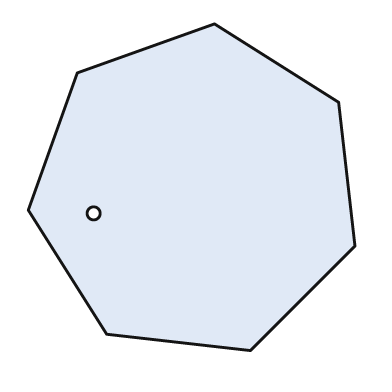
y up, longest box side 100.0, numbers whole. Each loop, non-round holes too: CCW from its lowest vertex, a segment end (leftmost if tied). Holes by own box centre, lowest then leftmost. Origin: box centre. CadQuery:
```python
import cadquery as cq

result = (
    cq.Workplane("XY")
    .moveTo(18.0, -50.0)
    .lineTo(50.0, -18.0)
    .lineTo(45.0, 26.0)
    .lineTo(7.0, 50.0)
    .lineTo(-35.0, 35.0)
    .lineTo(-50.0, -7.0)
    .lineTo(-26.0, -45.0)
    .close()
    .moveTo(-30.0, -8.0)
    .circle(2.0)
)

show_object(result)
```